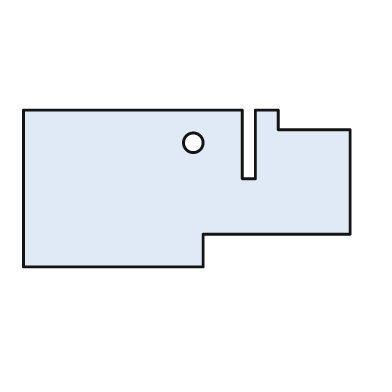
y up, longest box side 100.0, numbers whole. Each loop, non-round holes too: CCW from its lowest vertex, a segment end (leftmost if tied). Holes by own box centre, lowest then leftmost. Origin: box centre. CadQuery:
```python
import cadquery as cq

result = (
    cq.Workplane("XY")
    .moveTo(-50.0, -24.0)
    .lineTo(5.0, -24.0)
    .lineTo(5.0, -14.0)
    .lineTo(50.0, -14.0)
    .lineTo(50.0, 18.0)
    .lineTo(28.0, 18.0)
    .lineTo(28.0, 24.0)
    .lineTo(21.0, 24.0)
    .lineTo(21.0, 3.0)
    .lineTo(17.0, 3.0)
    .lineTo(17.0, 24.0)
    .lineTo(-50.0, 24.0)
    .close()
    .moveTo(2.0, 14.0)
    .circle(3.0)
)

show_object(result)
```